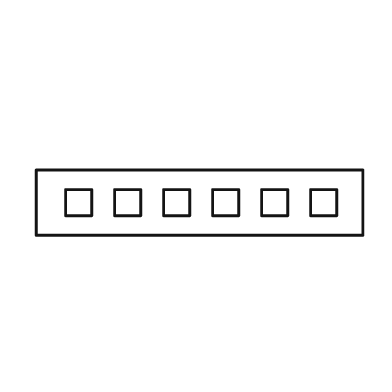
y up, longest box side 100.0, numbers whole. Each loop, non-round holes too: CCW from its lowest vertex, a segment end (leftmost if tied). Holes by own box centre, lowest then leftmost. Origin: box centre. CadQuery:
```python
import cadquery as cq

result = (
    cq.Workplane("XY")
    .moveTo(-50.0, -10.0)
    .lineTo(50.0, -10.0)
    .lineTo(50.0, 10.0)
    .lineTo(-50.0, 10.0)
    .close()
    .moveTo(-41.0, -4.0)
    .lineTo(-33.0, -4.0)
    .lineTo(-33.0, 4.0)
    .lineTo(-41.0, 4.0)
    .close()
    .moveTo(-26.0, -4.0)
    .lineTo(-18.0, -4.0)
    .lineTo(-18.0, 4.0)
    .lineTo(-26.0, 4.0)
    .close()
    .moveTo(-11.0, -4.0)
    .lineTo(-3.0, -4.0)
    .lineTo(-3.0, 4.0)
    .lineTo(-11.0, 4.0)
    .close()
    .moveTo(4.0, -4.0)
    .lineTo(12.0, -4.0)
    .lineTo(12.0, 4.0)
    .lineTo(4.0, 4.0)
    .close()
    .moveTo(19.0, -4.0)
    .lineTo(27.0, -4.0)
    .lineTo(27.0, 4.0)
    .lineTo(19.0, 4.0)
    .close()
    .moveTo(34.0, -4.0)
    .lineTo(42.0, -4.0)
    .lineTo(42.0, 4.0)
    .lineTo(34.0, 4.0)
    .close()
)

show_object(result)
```